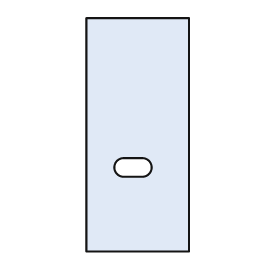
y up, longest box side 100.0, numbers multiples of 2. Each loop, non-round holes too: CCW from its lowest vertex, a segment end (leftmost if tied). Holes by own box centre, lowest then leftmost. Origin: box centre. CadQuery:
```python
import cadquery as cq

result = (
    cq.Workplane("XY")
    .moveTo(-22.0, -50.0)
    .lineTo(22.0, -50.0)
    .lineTo(22.0, 50.0)
    .lineTo(-22.0, 50.0)
    .close()
    .moveTo(-6.0, -18.0)
    .lineTo(2.0, -18.0)
    .threePointArc((6.0, -14.0), (2.0, -10.0))
    .lineTo(-6.0, -10.0)
    .threePointArc((-10.0, -14.0), (-6.0, -18.0))
    .close()
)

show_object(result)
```